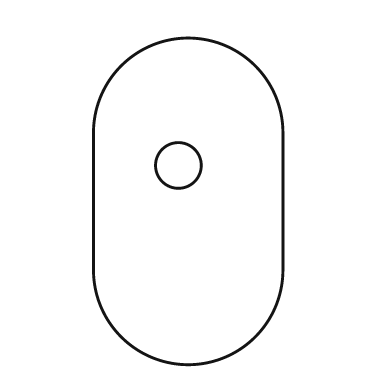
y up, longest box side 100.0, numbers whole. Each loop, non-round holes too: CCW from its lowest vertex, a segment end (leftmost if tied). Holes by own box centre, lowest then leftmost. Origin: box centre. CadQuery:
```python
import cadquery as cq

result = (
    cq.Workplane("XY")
    .moveTo(-29.0, -21.0)
    .threePointArc((0.0, -50.0), (29.0, -21.0))
    .lineTo(29.0, 21.0)
    .threePointArc((0.0, 50.0), (-29.0, 21.0))
    .close()
    .moveTo(-3.0, 11.0)
    .circle(7.0)
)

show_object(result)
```